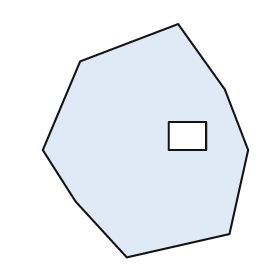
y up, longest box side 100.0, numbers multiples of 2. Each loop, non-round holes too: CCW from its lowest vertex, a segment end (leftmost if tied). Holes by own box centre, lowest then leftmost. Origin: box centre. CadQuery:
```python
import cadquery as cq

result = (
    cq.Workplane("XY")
    .moveTo(-8.0, -50.0)
    .lineTo(36.0, -40.0)
    .lineTo(44.0, -4.0)
    .lineTo(34.0, 22.0)
    .lineTo(14.0, 50.0)
    .lineTo(-28.0, 34.0)
    .lineTo(-44.0, -4.0)
    .lineTo(-30.0, -26.0)
    .close()
    .moveTo(10.0, -4.0)
    .lineTo(26.0, -4.0)
    .lineTo(26.0, 8.0)
    .lineTo(10.0, 8.0)
    .close()
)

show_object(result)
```